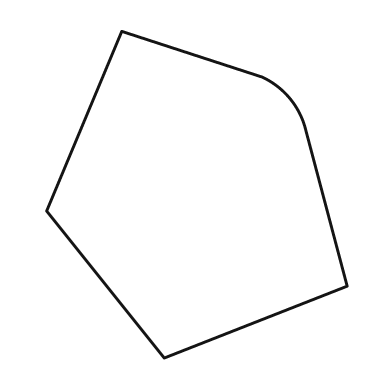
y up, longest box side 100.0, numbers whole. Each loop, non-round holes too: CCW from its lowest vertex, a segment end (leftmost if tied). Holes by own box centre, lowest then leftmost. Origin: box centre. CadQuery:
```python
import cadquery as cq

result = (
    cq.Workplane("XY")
    .moveTo(-10.0, -50.0)
    .lineTo(46.0, -28.0)
    .lineTo(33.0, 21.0)
    .threePointArc((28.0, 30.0), (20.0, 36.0))
    .lineTo(-23.0, 50.0)
    .lineTo(-46.0, -5.0)
    .close()
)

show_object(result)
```